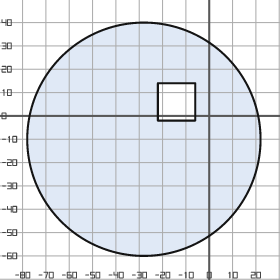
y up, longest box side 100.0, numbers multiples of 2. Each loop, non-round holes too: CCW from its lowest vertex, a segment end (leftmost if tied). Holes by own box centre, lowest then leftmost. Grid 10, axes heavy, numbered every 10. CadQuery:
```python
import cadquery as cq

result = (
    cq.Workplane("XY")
    .moveTo(-28.0, -10.0)
    .circle(50.0)
    .moveTo(-22.0, -2.0)
    .lineTo(-6.0, -2.0)
    .lineTo(-6.0, 14.0)
    .lineTo(-22.0, 14.0)
    .close()
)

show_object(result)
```